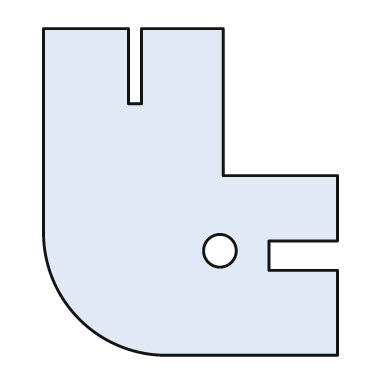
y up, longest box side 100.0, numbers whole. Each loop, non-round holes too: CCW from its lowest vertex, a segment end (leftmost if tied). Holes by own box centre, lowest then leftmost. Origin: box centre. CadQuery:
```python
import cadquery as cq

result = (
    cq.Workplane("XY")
    .moveTo(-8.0, -50.0)
    .lineTo(45.0, -50.0)
    .lineTo(45.0, -24.0)
    .lineTo(24.0, -24.0)
    .lineTo(24.0, -15.0)
    .lineTo(45.0, -15.0)
    .lineTo(45.0, 5.0)
    .lineTo(10.0, 5.0)
    .lineTo(10.0, 50.0)
    .lineTo(-15.0, 50.0)
    .lineTo(-15.0, 27.0)
    .lineTo(-19.0, 27.0)
    .lineTo(-19.0, 50.0)
    .lineTo(-45.0, 50.0)
    .lineTo(-45.0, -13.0)
    .threePointArc((-34.0, -39.0), (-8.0, -50.0))
    .close()
    .moveTo(9.0, -18.0)
    .circle(5.0)
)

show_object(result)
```